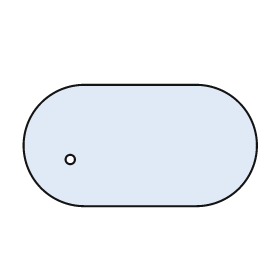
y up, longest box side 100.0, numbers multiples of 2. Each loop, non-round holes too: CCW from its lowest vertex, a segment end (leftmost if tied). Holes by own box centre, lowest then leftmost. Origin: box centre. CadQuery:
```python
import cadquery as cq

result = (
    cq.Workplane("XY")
    .moveTo(-24.0, -26.0)
    .lineTo(24.0, -26.0)
    .threePointArc((50.0, 0.0), (24.0, 26.0))
    .lineTo(-24.0, 26.0)
    .threePointArc((-50.0, 0.0), (-24.0, -26.0))
    .close()
    .moveTo(-30.0, -6.0)
    .circle(2.0)
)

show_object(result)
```